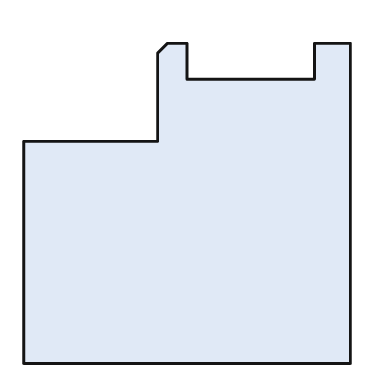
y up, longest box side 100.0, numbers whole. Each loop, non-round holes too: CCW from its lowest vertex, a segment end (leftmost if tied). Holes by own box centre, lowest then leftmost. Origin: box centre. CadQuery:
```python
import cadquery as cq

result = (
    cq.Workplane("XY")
    .moveTo(-50.0, -49.0)
    .lineTo(50.0, -49.0)
    .lineTo(50.0, 49.0)
    .lineTo(39.0, 49.0)
    .lineTo(39.0, 38.0)
    .lineTo(0.0, 38.0)
    .lineTo(0.0, 49.0)
    .lineTo(-6.0, 49.0)
    .lineTo(-9.0, 46.0)
    .lineTo(-9.0, 19.0)
    .lineTo(-50.0, 19.0)
    .close()
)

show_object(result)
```